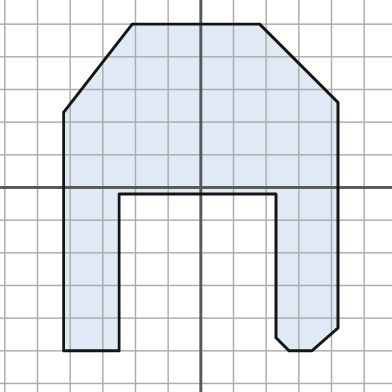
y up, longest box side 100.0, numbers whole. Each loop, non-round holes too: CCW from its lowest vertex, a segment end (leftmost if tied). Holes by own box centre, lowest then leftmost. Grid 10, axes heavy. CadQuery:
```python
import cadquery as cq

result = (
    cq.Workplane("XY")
    .moveTo(-42.0, -50.0)
    .lineTo(-25.0, -50.0)
    .lineTo(-25.0, -2.0)
    .lineTo(23.0, -2.0)
    .lineTo(23.0, -46.0)
    .lineTo(27.0, -50.0)
    .lineTo(34.0, -50.0)
    .lineTo(42.0, -43.0)
    .lineTo(42.0, 26.0)
    .lineTo(18.0, 50.0)
    .lineTo(-21.0, 50.0)
    .lineTo(-42.0, 23.0)
    .close()
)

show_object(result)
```